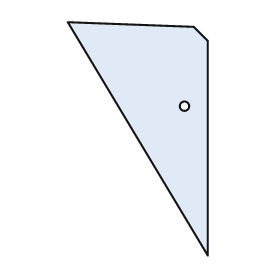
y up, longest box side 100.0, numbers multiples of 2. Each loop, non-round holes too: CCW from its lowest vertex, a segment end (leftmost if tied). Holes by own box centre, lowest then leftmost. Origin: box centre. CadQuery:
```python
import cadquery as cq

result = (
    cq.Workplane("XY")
    .moveTo(30.0, -50.0)
    .lineTo(30.0, 42.0)
    .lineTo(24.0, 48.0)
    .lineTo(-30.0, 50.0)
    .close()
    .moveTo(20.0, 14.0)
    .circle(2.0)
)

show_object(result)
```